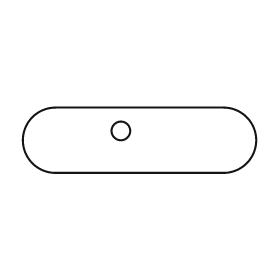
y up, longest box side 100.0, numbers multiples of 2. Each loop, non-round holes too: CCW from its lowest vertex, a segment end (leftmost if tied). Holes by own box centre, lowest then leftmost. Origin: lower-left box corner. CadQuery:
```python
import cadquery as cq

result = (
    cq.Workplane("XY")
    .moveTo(14.0, 0.0)
    .lineTo(86.0, 0.0)
    .threePointArc((100.0, 14.0), (86.0, 28.0))
    .lineTo(14.0, 28.0)
    .threePointArc((0.0, 14.0), (14.0, 0.0))
    .close()
    .moveTo(42.0, 18.0)
    .circle(4.0)
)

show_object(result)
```